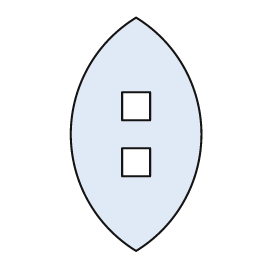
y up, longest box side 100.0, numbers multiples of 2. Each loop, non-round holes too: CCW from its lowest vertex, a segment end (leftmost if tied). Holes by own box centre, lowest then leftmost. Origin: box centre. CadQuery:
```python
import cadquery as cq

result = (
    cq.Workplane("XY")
    .moveTo(0.0, -50.0)
    .threePointArc((28.0, 0.0), (0.0, 50.0))
    .threePointArc((-28.0, 0.0), (0.0, -50.0))
    .close()
    .moveTo(-6.0, -18.0)
    .lineTo(6.0, -18.0)
    .lineTo(6.0, -6.0)
    .lineTo(-6.0, -6.0)
    .close()
    .moveTo(-6.0, 6.0)
    .lineTo(6.0, 6.0)
    .lineTo(6.0, 18.0)
    .lineTo(-6.0, 18.0)
    .close()
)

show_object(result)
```